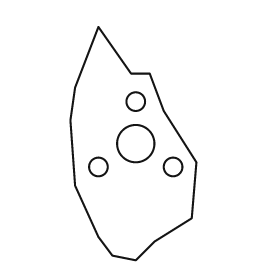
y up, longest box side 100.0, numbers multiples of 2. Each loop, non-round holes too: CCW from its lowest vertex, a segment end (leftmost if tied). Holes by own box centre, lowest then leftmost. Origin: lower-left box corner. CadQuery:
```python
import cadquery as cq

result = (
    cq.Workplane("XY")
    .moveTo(28.0, 0.0)
    .lineTo(36.0, 8.0)
    .lineTo(52.0, 18.0)
    .lineTo(54.0, 42.0)
    .lineTo(40.0, 64.0)
    .lineTo(34.0, 80.0)
    .lineTo(26.0, 80.0)
    .lineTo(12.0, 100.0)
    .lineTo(2.0, 74.0)
    .lineTo(0.0, 60.0)
    .lineTo(2.0, 32.0)
    .lineTo(12.0, 10.0)
    .lineTo(18.0, 2.0)
    .close()
    .moveTo(12.0, 40.0)
    .circle(4.0)
    .moveTo(44.0, 40.0)
    .circle(4.0)
    .moveTo(28.0, 50.0)
    .circle(8.0)
    .moveTo(28.0, 68.0)
    .circle(4.0)
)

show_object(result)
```